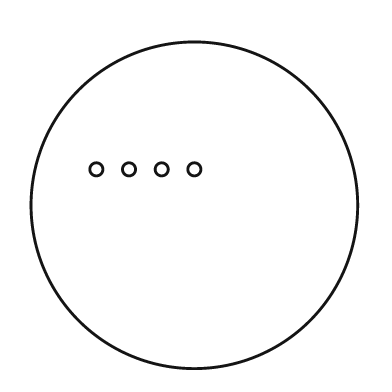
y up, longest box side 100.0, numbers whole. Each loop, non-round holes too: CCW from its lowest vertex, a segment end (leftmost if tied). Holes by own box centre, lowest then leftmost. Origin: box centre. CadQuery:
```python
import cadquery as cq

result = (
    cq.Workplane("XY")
    .moveTo(0.0, 0.0)
    .circle(50.0)
    .moveTo(-30.0, 11.0)
    .circle(2.0)
    .moveTo(-20.0, 11.0)
    .circle(2.0)
    .moveTo(-10.0, 11.0)
    .circle(2.0)
    .moveTo(0.0, 11.0)
    .circle(2.0)
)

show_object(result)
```